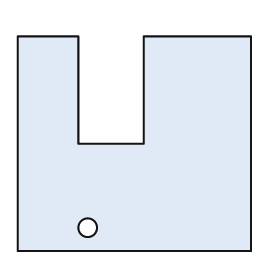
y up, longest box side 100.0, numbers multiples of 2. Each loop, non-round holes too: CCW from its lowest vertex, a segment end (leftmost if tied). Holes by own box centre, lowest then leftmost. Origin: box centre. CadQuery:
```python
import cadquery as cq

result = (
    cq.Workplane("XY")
    .moveTo(-50.0, -46.0)
    .lineTo(50.0, -46.0)
    .lineTo(50.0, 46.0)
    .lineTo(4.0, 46.0)
    .lineTo(4.0, 0.0)
    .lineTo(-24.0, 0.0)
    .lineTo(-24.0, 46.0)
    .lineTo(-50.0, 46.0)
    .close()
    .moveTo(-20.0, -36.0)
    .circle(4.0)
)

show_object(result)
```